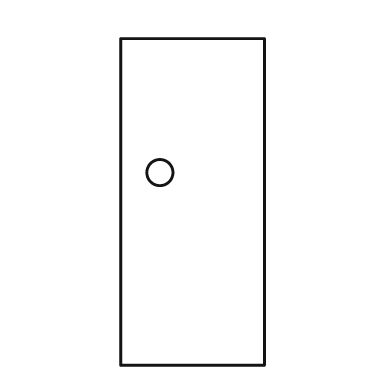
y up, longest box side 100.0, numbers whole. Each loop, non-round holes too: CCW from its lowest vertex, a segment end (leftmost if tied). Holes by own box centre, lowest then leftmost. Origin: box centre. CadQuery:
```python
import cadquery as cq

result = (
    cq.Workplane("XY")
    .moveTo(-22.0, -50.0)
    .lineTo(22.0, -50.0)
    .lineTo(22.0, 50.0)
    .lineTo(-22.0, 50.0)
    .close()
    .moveTo(-10.0, 9.0)
    .circle(4.0)
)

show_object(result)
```